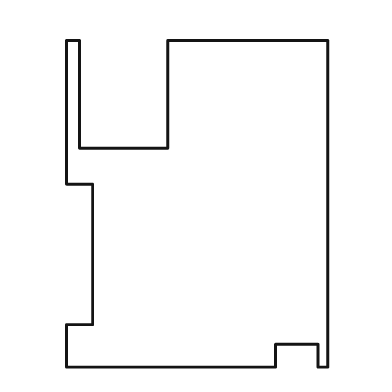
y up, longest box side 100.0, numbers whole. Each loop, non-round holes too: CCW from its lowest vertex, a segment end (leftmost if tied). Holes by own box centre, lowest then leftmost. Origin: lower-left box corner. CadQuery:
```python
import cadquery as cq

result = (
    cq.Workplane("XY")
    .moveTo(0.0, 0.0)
    .lineTo(64.0, 0.0)
    .lineTo(64.0, 7.0)
    .lineTo(77.0, 7.0)
    .lineTo(77.0, 0.0)
    .lineTo(80.0, 0.0)
    .lineTo(80.0, 100.0)
    .lineTo(31.0, 100.0)
    .lineTo(31.0, 67.0)
    .lineTo(4.0, 67.0)
    .lineTo(4.0, 100.0)
    .lineTo(0.0, 100.0)
    .lineTo(0.0, 56.0)
    .lineTo(8.0, 56.0)
    .lineTo(8.0, 13.0)
    .lineTo(0.0, 13.0)
    .close()
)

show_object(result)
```